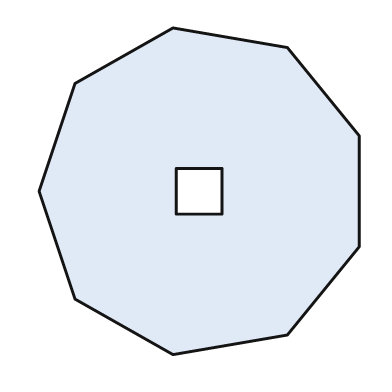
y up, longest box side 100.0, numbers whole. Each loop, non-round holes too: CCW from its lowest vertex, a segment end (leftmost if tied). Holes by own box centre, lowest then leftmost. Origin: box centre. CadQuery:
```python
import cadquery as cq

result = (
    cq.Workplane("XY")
    .moveTo(-8.0, -50.0)
    .lineTo(27.0, -44.0)
    .lineTo(49.0, -17.0)
    .lineTo(49.0, 17.0)
    .lineTo(27.0, 44.0)
    .lineTo(-8.0, 50.0)
    .lineTo(-38.0, 33.0)
    .lineTo(-49.0, 0.0)
    .lineTo(-38.0, -33.0)
    .close()
    .moveTo(-7.0, -7.0)
    .lineTo(7.0, -7.0)
    .lineTo(7.0, 7.0)
    .lineTo(-7.0, 7.0)
    .close()
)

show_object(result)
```